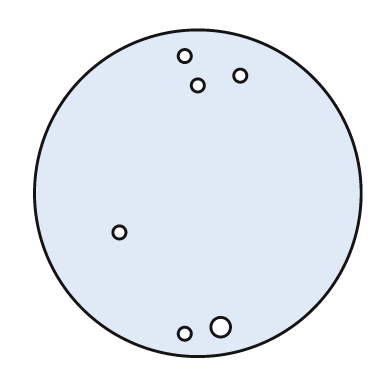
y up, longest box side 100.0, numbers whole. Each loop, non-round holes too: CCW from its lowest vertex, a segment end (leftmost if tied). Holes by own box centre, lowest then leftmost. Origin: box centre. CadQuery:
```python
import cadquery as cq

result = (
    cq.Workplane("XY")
    .moveTo(0.0, 0.0)
    .circle(50.0)
    .moveTo(-4.0, -43.0)
    .circle(2.0)
    .moveTo(7.0, -41.0)
    .circle(3.0)
    .moveTo(-24.0, -12.0)
    .circle(2.0)
    .moveTo(0.0, 33.0)
    .circle(2.0)
    .moveTo(13.0, 36.0)
    .circle(2.0)
    .moveTo(-4.0, 42.0)
    .circle(2.0)
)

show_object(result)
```